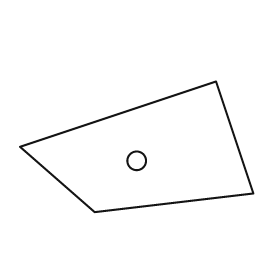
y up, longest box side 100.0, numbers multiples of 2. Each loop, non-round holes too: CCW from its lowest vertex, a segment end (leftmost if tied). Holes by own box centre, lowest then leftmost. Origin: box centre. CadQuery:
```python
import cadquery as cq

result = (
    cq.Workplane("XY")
    .moveTo(-18.0, -28.0)
    .lineTo(50.0, -20.0)
    .lineTo(34.0, 28.0)
    .lineTo(-50.0, 0.0)
    .close()
    .moveTo(0.0, -6.0)
    .circle(4.0)
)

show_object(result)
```